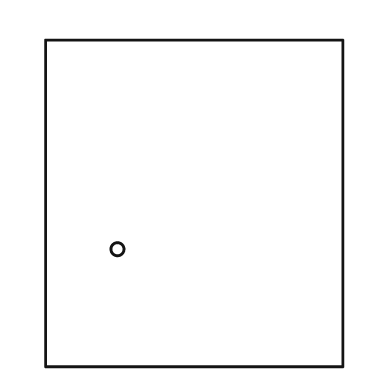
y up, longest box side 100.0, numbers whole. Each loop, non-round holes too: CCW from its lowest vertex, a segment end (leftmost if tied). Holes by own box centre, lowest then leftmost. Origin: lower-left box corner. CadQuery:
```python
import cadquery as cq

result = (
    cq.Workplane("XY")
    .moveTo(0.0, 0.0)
    .lineTo(91.0, 0.0)
    .lineTo(91.0, 100.0)
    .lineTo(0.0, 100.0)
    .close()
    .moveTo(22.0, 36.0)
    .circle(2.0)
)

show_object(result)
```